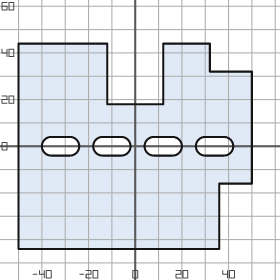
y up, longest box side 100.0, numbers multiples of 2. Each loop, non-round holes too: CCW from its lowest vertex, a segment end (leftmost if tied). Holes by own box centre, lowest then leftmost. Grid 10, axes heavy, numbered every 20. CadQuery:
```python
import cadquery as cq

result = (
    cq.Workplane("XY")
    .moveTo(-50.0, -44.0)
    .lineTo(36.0, -44.0)
    .lineTo(36.0, -16.0)
    .lineTo(50.0, -16.0)
    .lineTo(50.0, 32.0)
    .lineTo(32.0, 32.0)
    .lineTo(32.0, 44.0)
    .lineTo(12.0, 44.0)
    .lineTo(12.0, 18.0)
    .lineTo(-12.0, 18.0)
    .lineTo(-12.0, 44.0)
    .lineTo(-50.0, 44.0)
    .close()
    .moveTo(-36.0, -4.0)
    .lineTo(-28.0, -4.0)
    .threePointArc((-24.0, 0.0), (-28.0, 4.0))
    .lineTo(-36.0, 4.0)
    .threePointArc((-40.0, 0.0), (-36.0, -4.0))
    .close()
    .moveTo(-14.0, -4.0)
    .lineTo(-6.0, -4.0)
    .threePointArc((-2.0, 0.0), (-6.0, 4.0))
    .lineTo(-14.0, 4.0)
    .threePointArc((-18.0, 0.0), (-14.0, -4.0))
    .close()
    .moveTo(8.0, -4.0)
    .lineTo(16.0, -4.0)
    .threePointArc((20.0, 0.0), (16.0, 4.0))
    .lineTo(8.0, 4.0)
    .threePointArc((4.0, 0.0), (8.0, -4.0))
    .close()
    .moveTo(30.0, -4.0)
    .lineTo(38.0, -4.0)
    .threePointArc((42.0, 0.0), (38.0, 4.0))
    .lineTo(30.0, 4.0)
    .threePointArc((26.0, 0.0), (30.0, -4.0))
    .close()
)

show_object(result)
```